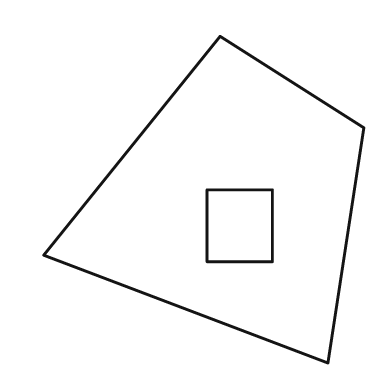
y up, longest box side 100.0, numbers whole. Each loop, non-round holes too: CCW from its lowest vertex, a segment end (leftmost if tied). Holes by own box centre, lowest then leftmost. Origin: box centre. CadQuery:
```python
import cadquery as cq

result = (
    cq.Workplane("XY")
    .moveTo(38.0, -50.0)
    .lineTo(49.0, 22.0)
    .lineTo(5.0, 50.0)
    .lineTo(-49.0, -17.0)
    .close()
    .moveTo(1.0, -19.0)
    .lineTo(21.0, -19.0)
    .lineTo(21.0, 3.0)
    .lineTo(1.0, 3.0)
    .close()
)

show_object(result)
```